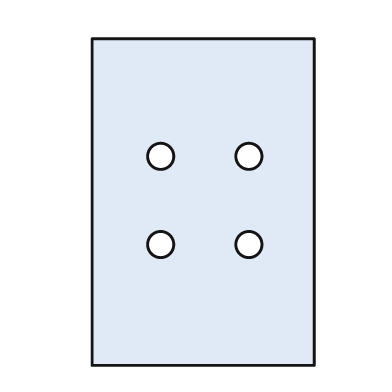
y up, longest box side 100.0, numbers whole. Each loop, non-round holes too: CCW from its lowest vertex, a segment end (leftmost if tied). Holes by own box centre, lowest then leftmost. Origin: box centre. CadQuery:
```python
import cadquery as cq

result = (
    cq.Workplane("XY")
    .moveTo(-34.0, -50.0)
    .lineTo(34.0, -50.0)
    .lineTo(34.0, 50.0)
    .lineTo(-34.0, 50.0)
    .close()
    .moveTo(-13.0, -13.0)
    .circle(4.0)
    .moveTo(14.0, -13.0)
    .circle(4.0)
    .moveTo(-13.0, 14.0)
    .circle(4.0)
    .moveTo(14.0, 14.0)
    .circle(4.0)
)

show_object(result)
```